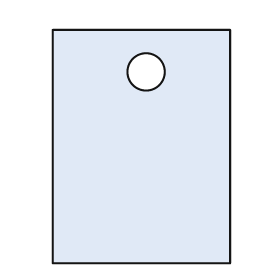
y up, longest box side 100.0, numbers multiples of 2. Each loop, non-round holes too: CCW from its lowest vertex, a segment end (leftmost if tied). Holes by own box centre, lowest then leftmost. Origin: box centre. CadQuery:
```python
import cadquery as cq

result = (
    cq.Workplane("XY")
    .moveTo(-38.0, -50.0)
    .lineTo(38.0, -50.0)
    .lineTo(38.0, 50.0)
    .lineTo(-38.0, 50.0)
    .close()
    .moveTo(2.0, 32.0)
    .circle(8.0)
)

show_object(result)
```